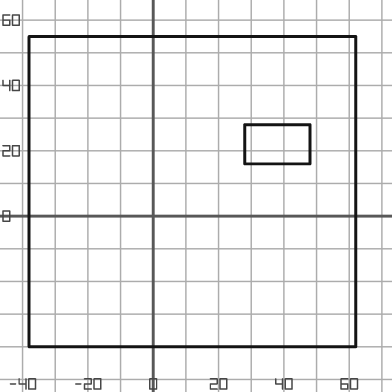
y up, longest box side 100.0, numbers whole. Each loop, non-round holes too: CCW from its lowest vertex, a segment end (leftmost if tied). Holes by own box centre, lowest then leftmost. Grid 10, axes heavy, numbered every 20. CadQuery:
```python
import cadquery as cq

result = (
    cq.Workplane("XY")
    .moveTo(-38.0, -40.0)
    .lineTo(62.0, -40.0)
    .lineTo(62.0, 55.0)
    .lineTo(-38.0, 55.0)
    .close()
    .moveTo(28.0, 16.0)
    .lineTo(48.0, 16.0)
    .lineTo(48.0, 28.0)
    .lineTo(28.0, 28.0)
    .close()
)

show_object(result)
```